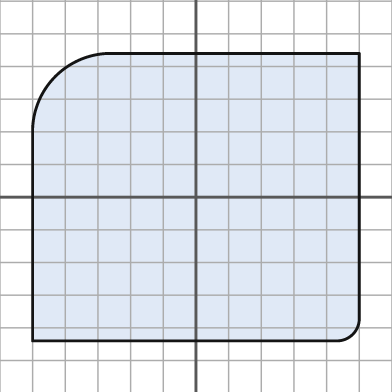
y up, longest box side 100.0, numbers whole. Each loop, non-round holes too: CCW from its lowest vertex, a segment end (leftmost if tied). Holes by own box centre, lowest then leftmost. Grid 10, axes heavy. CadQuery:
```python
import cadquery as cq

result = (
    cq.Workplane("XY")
    .moveTo(-50.0, -44.0)
    .lineTo(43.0, -44.0)
    .threePointArc((48.0, -42.0), (50.0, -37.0))
    .lineTo(50.0, 44.0)
    .lineTo(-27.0, 44.0)
    .threePointArc((-43.0, 37.0), (-50.0, 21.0))
    .close()
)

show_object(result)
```